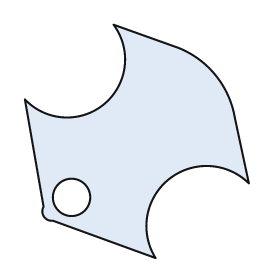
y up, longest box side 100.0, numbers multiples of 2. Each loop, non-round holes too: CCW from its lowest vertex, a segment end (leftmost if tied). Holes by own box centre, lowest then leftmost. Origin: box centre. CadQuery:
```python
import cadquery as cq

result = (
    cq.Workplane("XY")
    .moveTo(8.0, -50.0)
    .threePointArc((14.0, -16.0), (48.0, -18.0))
    .lineTo(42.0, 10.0)
    .threePointArc((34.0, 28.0), (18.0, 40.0))
    .lineTo(-10.0, 50.0)
    .threePointArc((-14.0, 16.0), (-48.0, 18.0))
    .lineTo(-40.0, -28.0)
    .threePointArc((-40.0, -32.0), (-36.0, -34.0))
    .close()
    .moveTo(-28.0, -24.0)
    .circle(8.0)
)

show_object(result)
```